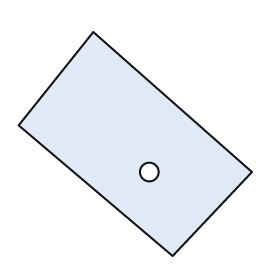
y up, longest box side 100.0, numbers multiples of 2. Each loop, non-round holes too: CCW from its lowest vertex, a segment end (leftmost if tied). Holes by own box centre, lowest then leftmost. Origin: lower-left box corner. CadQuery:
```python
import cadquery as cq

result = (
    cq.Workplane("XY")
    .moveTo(66.0, 0.0)
    .lineTo(100.0, 36.0)
    .lineTo(32.0, 96.0)
    .lineTo(0.0, 56.0)
    .close()
    .moveTo(56.0, 36.0)
    .circle(4.0)
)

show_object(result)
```